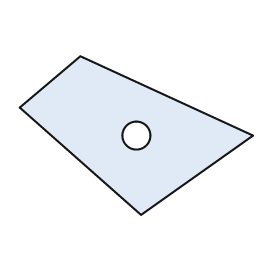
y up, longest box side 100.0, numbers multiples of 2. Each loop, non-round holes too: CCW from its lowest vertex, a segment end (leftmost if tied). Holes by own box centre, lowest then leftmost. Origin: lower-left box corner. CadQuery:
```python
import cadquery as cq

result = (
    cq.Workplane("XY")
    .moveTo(52.0, 0.0)
    .lineTo(100.0, 34.0)
    .lineTo(26.0, 68.0)
    .lineTo(0.0, 46.0)
    .close()
    .moveTo(50.0, 34.0)
    .circle(6.0)
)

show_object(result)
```